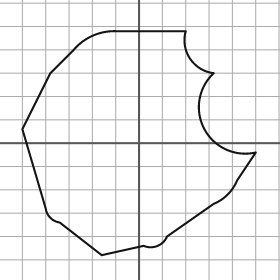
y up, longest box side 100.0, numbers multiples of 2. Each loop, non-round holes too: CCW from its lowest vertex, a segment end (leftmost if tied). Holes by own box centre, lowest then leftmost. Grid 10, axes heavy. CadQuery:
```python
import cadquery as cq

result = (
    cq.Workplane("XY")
    .moveTo(-16.0, -48.0)
    .lineTo(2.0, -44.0)
    .threePointArc((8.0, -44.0), (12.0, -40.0))
    .lineTo(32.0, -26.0)
    .threePointArc((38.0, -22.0), (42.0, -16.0))
    .lineTo(50.0, -4.0)
    .threePointArc((28.0, 6.0), (32.0, 30.0))
    .threePointArc((22.0, 36.0), (20.0, 48.0))
    .lineTo(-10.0, 48.0)
    .threePointArc((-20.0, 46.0), (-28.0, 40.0))
    .lineTo(-38.0, 30.0)
    .lineTo(-50.0, 6.0)
    .lineTo(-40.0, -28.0)
    .threePointArc((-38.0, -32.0), (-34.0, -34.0))
    .close()
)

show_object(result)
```